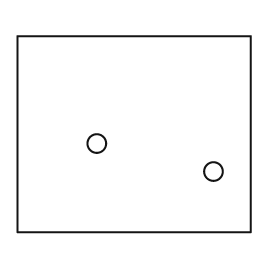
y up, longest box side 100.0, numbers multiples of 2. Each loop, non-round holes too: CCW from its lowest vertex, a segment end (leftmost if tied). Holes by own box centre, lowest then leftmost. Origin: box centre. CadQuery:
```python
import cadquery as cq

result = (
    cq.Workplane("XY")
    .moveTo(-50.0, -42.0)
    .lineTo(50.0, -42.0)
    .lineTo(50.0, 42.0)
    .lineTo(-50.0, 42.0)
    .close()
    .moveTo(34.0, -16.0)
    .circle(4.0)
    .moveTo(-16.0, -4.0)
    .circle(4.0)
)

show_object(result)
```